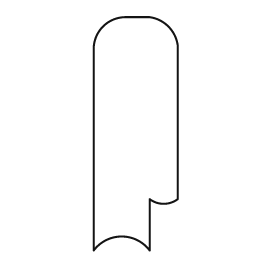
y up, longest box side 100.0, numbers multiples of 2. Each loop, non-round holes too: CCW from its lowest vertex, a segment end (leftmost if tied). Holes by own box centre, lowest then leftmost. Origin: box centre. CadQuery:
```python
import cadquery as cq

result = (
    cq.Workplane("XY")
    .moveTo(-18.0, -50.0)
    .threePointArc((-6.0, -44.0), (6.0, -50.0))
    .lineTo(6.0, -28.0)
    .threePointArc((12.0, -30.0), (18.0, -28.0))
    .lineTo(18.0, 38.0)
    .threePointArc((14.0, 46.0), (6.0, 50.0))
    .lineTo(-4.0, 50.0)
    .threePointArc((-14.0, 46.0), (-18.0, 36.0))
    .close()
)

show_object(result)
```